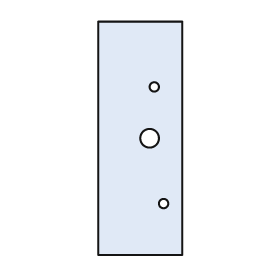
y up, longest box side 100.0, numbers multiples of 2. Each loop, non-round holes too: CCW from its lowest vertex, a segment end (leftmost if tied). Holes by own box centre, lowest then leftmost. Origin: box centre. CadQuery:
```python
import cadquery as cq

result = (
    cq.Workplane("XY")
    .moveTo(-18.0, -50.0)
    .lineTo(18.0, -50.0)
    .lineTo(18.0, 50.0)
    .lineTo(-18.0, 50.0)
    .close()
    .moveTo(10.0, -28.0)
    .circle(2.0)
    .moveTo(4.0, 0.0)
    .circle(4.0)
    .moveTo(6.0, 22.0)
    .circle(2.0)
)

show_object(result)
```